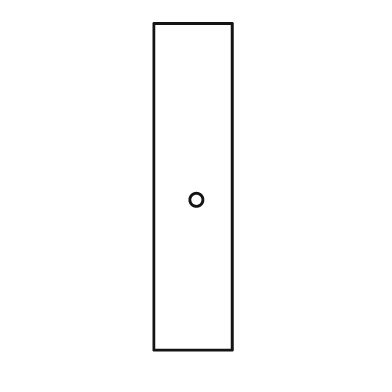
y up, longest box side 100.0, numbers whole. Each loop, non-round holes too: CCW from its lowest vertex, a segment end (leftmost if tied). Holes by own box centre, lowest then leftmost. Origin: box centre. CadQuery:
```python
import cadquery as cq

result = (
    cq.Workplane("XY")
    .moveTo(-12.0, -50.0)
    .lineTo(12.0, -50.0)
    .lineTo(12.0, 50.0)
    .lineTo(-12.0, 50.0)
    .close()
    .moveTo(1.0, -4.0)
    .circle(2.0)
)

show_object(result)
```